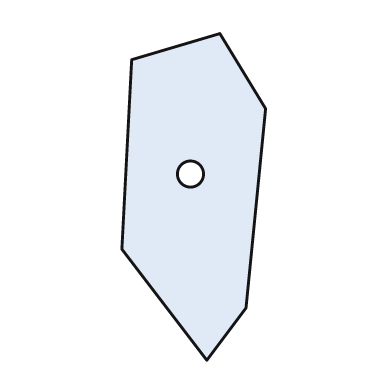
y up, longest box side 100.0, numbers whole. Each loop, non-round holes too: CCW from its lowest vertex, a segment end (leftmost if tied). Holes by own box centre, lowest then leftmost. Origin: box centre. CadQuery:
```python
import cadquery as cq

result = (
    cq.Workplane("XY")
    .moveTo(4.0, -50.0)
    .lineTo(16.0, -34.0)
    .lineTo(22.0, 27.0)
    .lineTo(8.0, 50.0)
    .lineTo(-19.0, 42.0)
    .lineTo(-22.0, -16.0)
    .close()
    .moveTo(-1.0, 7.0)
    .circle(4.0)
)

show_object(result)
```